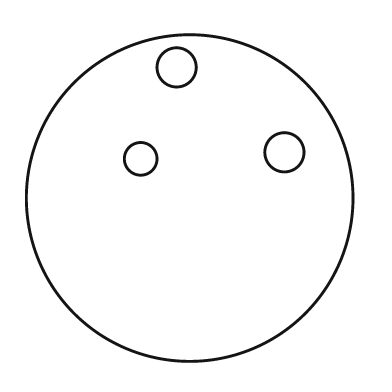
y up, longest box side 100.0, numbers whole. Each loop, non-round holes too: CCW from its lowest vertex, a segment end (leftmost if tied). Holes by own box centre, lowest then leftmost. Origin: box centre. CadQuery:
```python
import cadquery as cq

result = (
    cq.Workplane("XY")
    .moveTo(0.0, 0.0)
    .circle(50.0)
    .moveTo(-15.0, 12.0)
    .circle(5.0)
    .moveTo(29.0, 14.0)
    .circle(6.0)
    .moveTo(-4.0, 40.0)
    .circle(6.0)
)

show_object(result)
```